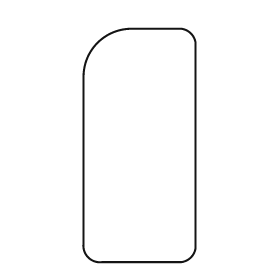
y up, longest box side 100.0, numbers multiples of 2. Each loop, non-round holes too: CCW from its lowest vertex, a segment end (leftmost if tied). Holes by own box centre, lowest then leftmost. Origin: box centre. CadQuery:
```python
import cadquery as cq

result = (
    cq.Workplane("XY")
    .moveTo(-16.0, -50.0)
    .lineTo(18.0, -50.0)
    .threePointArc((22.0, -48.0), (24.0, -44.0))
    .lineTo(24.0, 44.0)
    .threePointArc((22.0, 48.0), (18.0, 50.0))
    .lineTo(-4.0, 50.0)
    .threePointArc((-18.0, 44.0), (-24.0, 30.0))
    .lineTo(-24.0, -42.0)
    .threePointArc((-22.0, -48.0), (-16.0, -50.0))
    .close()
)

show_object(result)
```